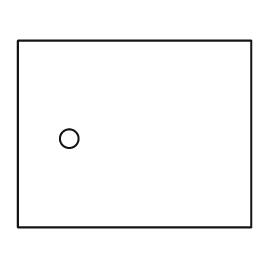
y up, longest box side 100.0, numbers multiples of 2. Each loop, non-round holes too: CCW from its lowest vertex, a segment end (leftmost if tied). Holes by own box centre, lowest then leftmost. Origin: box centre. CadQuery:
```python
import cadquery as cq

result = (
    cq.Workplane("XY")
    .moveTo(-50.0, -40.0)
    .lineTo(50.0, -40.0)
    .lineTo(50.0, 40.0)
    .lineTo(-50.0, 40.0)
    .close()
    .moveTo(-28.0, -2.0)
    .circle(4.0)
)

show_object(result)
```